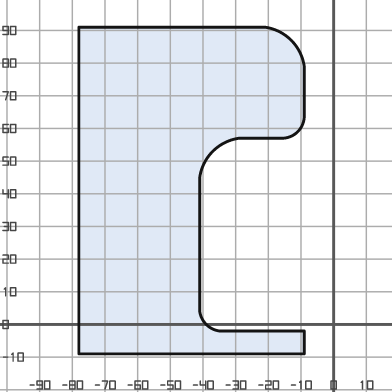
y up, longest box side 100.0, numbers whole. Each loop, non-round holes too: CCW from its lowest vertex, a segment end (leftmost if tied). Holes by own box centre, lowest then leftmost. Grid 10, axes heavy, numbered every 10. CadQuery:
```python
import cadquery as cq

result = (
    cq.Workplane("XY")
    .moveTo(-78.0, -9.0)
    .lineTo(-9.0, -9.0)
    .lineTo(-9.0, -2.0)
    .lineTo(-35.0, -2.0)
    .threePointArc((-39.0, 0.0), (-41.0, 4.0))
    .lineTo(-41.0, 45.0)
    .threePointArc((-37.0, 53.0), (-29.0, 57.0))
    .lineTo(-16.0, 57.0)
    .threePointArc((-11.0, 59.0), (-9.0, 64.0))
    .lineTo(-9.0, 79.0)
    .threePointArc((-13.0, 87.0), (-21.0, 91.0))
    .lineTo(-78.0, 91.0)
    .close()
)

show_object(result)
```